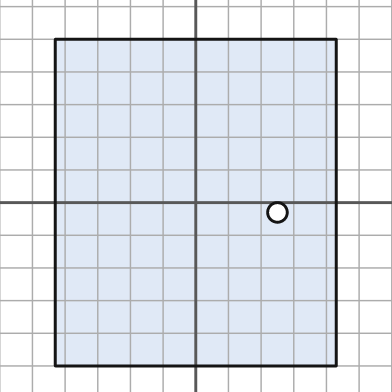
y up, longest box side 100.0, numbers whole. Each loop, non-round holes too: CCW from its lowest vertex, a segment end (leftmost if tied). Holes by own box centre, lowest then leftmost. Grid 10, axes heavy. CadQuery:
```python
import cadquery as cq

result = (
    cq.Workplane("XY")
    .moveTo(-43.0, -50.0)
    .lineTo(43.0, -50.0)
    .lineTo(43.0, 50.0)
    .lineTo(-43.0, 50.0)
    .close()
    .moveTo(25.0, -3.0)
    .circle(3.0)
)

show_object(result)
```